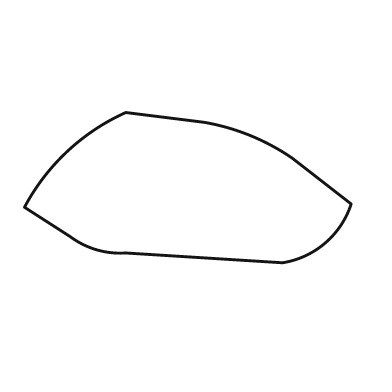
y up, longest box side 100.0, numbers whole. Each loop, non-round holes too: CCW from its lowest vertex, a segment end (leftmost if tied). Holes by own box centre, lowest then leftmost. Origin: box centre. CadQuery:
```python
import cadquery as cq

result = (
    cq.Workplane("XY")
    .moveTo(29.0, -23.0)
    .threePointArc((42.0, -17.0), (50.0, -5.0))
    .lineTo(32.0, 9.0)
    .threePointArc((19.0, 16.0), (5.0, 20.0))
    .lineTo(-19.0, 23.0)
    .threePointArc((-37.0, 11.0), (-50.0, -6.0))
    .lineTo(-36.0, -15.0)
    .threePointArc((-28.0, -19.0), (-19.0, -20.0))
    .close()
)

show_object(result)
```